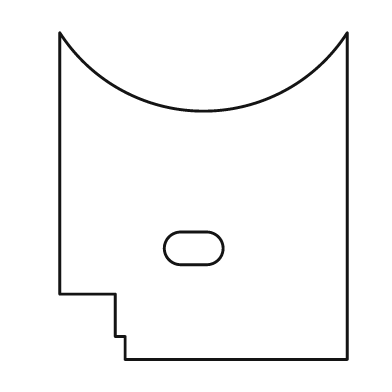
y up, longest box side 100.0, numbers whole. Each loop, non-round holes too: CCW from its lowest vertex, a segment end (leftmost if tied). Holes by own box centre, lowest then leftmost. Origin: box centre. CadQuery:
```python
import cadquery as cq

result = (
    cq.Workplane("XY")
    .moveTo(-24.0, -50.0)
    .lineTo(44.0, -50.0)
    .lineTo(44.0, 50.0)
    .threePointArc((0.0, 26.0), (-44.0, 50.0))
    .lineTo(-44.0, -30.0)
    .lineTo(-27.0, -30.0)
    .lineTo(-27.0, -43.0)
    .lineTo(-24.0, -43.0)
    .close()
    .moveTo(-7.0, -21.0)
    .lineTo(1.0, -21.0)
    .threePointArc((6.0, -16.0), (1.0, -11.0))
    .lineTo(-7.0, -11.0)
    .threePointArc((-12.0, -16.0), (-7.0, -21.0))
    .close()
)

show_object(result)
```